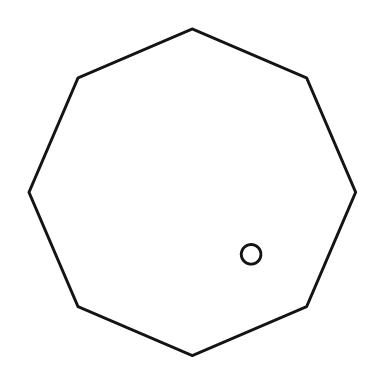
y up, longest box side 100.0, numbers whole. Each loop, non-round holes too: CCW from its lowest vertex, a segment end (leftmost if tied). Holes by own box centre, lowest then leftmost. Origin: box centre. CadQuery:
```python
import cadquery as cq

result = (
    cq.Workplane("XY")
    .moveTo(0.0, -50.0)
    .lineTo(35.0, -35.0)
    .lineTo(50.0, 0.0)
    .lineTo(35.0, 35.0)
    .lineTo(0.0, 50.0)
    .lineTo(-35.0, 35.0)
    .lineTo(-50.0, 0.0)
    .lineTo(-35.0, -35.0)
    .close()
    .moveTo(18.0, -19.0)
    .circle(3.0)
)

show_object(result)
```